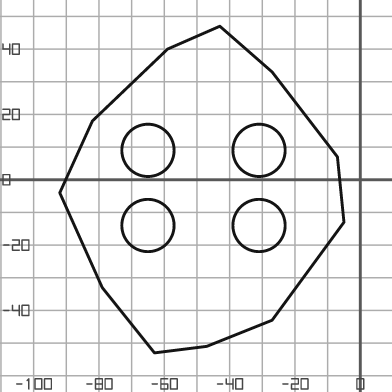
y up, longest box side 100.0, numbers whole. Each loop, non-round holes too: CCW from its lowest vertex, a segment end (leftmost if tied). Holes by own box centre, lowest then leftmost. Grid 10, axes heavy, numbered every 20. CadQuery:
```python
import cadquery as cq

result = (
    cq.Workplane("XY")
    .moveTo(-63.0, -53.0)
    .lineTo(-47.0, -51.0)
    .lineTo(-27.0, -43.0)
    .lineTo(-5.0, -13.0)
    .lineTo(-7.0, 7.0)
    .lineTo(-27.0, 33.0)
    .lineTo(-43.0, 47.0)
    .lineTo(-59.0, 40.0)
    .lineTo(-82.0, 18.0)
    .lineTo(-92.0, -4.0)
    .lineTo(-79.0, -33.0)
    .close()
    .moveTo(-65.0, -14.0)
    .circle(8.0)
    .moveTo(-31.0, -14.0)
    .circle(8.0)
    .moveTo(-65.0, 9.0)
    .circle(8.0)
    .moveTo(-31.0, 9.0)
    .circle(8.0)
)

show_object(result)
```